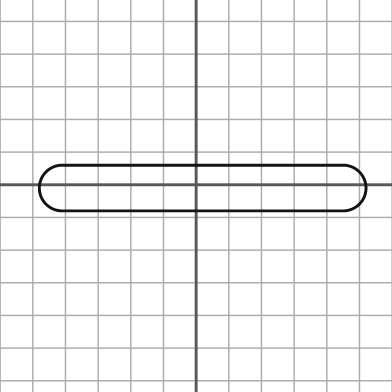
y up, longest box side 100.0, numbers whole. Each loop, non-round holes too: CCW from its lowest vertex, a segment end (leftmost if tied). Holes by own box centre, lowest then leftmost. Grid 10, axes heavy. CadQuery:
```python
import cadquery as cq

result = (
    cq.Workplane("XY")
    .moveTo(-41.0, -8.0)
    .lineTo(45.0, -8.0)
    .threePointArc((52.0, -1.0), (45.0, 6.0))
    .lineTo(-41.0, 6.0)
    .threePointArc((-48.0, -1.0), (-41.0, -8.0))
    .close()
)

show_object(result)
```